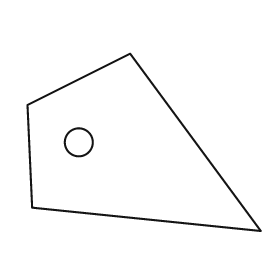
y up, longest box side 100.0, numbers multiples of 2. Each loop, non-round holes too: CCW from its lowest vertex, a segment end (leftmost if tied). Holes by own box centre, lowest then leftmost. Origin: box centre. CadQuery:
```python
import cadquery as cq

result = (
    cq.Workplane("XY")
    .moveTo(50.0, -38.0)
    .lineTo(-6.0, 38.0)
    .lineTo(-50.0, 16.0)
    .lineTo(-48.0, -28.0)
    .close()
    .moveTo(-28.0, 0.0)
    .circle(6.0)
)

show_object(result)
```